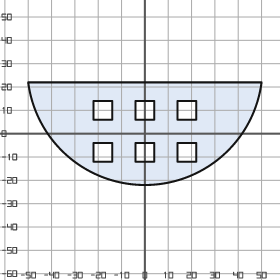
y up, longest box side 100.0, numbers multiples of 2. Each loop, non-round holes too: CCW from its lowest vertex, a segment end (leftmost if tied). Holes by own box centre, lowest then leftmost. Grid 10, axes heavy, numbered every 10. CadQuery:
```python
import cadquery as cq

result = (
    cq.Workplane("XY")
    .moveTo(-50.0, 22.0)
    .threePointArc((0.0, -22.0), (50.0, 22.0))
    .close()
    .moveTo(-22.0, -12.0)
    .lineTo(-14.0, -12.0)
    .lineTo(-14.0, -4.0)
    .lineTo(-22.0, -4.0)
    .close()
    .moveTo(-4.0, -12.0)
    .lineTo(4.0, -12.0)
    .lineTo(4.0, -4.0)
    .lineTo(-4.0, -4.0)
    .close()
    .moveTo(14.0, -12.0)
    .lineTo(22.0, -12.0)
    .lineTo(22.0, -4.0)
    .lineTo(14.0, -4.0)
    .close()
    .moveTo(-22.0, 6.0)
    .lineTo(-14.0, 6.0)
    .lineTo(-14.0, 14.0)
    .lineTo(-22.0, 14.0)
    .close()
    .moveTo(-4.0, 6.0)
    .lineTo(4.0, 6.0)
    .lineTo(4.0, 14.0)
    .lineTo(-4.0, 14.0)
    .close()
    .moveTo(14.0, 6.0)
    .lineTo(22.0, 6.0)
    .lineTo(22.0, 14.0)
    .lineTo(14.0, 14.0)
    .close()
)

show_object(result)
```